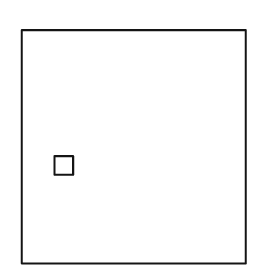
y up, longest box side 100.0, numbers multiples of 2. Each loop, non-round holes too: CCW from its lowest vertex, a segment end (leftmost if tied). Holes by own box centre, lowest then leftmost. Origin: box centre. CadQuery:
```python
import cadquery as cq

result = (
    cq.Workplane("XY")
    .moveTo(-48.0, -50.0)
    .lineTo(48.0, -50.0)
    .lineTo(48.0, 50.0)
    .lineTo(-48.0, 50.0)
    .close()
    .moveTo(-34.0, -12.0)
    .lineTo(-26.0, -12.0)
    .lineTo(-26.0, -4.0)
    .lineTo(-34.0, -4.0)
    .close()
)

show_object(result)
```